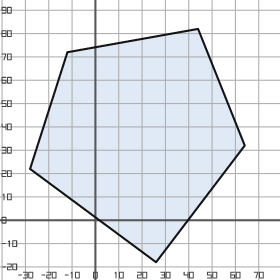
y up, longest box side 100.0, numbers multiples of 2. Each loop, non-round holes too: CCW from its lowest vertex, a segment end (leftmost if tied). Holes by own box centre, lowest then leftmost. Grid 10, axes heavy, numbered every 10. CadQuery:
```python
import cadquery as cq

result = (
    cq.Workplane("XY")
    .moveTo(26.0, -18.0)
    .lineTo(64.0, 32.0)
    .lineTo(44.0, 82.0)
    .lineTo(-12.0, 72.0)
    .lineTo(-28.0, 22.0)
    .close()
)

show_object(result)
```